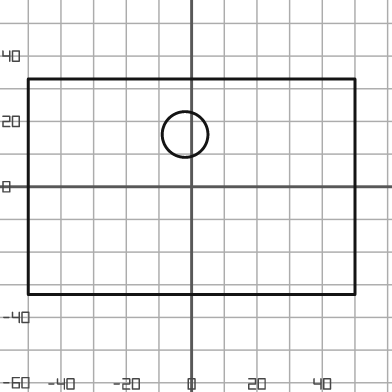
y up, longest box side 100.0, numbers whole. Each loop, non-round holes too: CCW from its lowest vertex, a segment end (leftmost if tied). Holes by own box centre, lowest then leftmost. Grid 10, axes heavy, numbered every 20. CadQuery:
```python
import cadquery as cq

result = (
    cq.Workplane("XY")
    .moveTo(-50.0, -33.0)
    .lineTo(50.0, -33.0)
    .lineTo(50.0, 33.0)
    .lineTo(-50.0, 33.0)
    .close()
    .moveTo(-2.0, 16.0)
    .circle(7.0)
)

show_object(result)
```